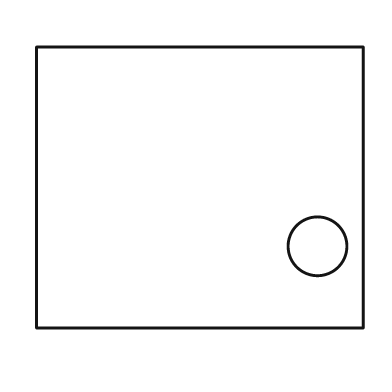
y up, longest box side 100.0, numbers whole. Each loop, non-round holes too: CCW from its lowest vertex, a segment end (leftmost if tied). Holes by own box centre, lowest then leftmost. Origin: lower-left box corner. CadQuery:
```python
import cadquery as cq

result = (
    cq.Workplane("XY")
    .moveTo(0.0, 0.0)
    .lineTo(100.0, 0.0)
    .lineTo(100.0, 86.0)
    .lineTo(0.0, 86.0)
    .close()
    .moveTo(86.0, 25.0)
    .circle(9.0)
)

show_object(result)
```